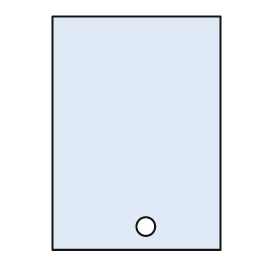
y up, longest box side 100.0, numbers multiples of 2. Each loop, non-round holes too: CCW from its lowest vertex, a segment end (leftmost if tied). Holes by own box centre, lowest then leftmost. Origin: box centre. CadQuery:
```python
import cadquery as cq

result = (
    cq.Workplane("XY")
    .moveTo(-36.0, -50.0)
    .lineTo(36.0, -50.0)
    .lineTo(36.0, 50.0)
    .lineTo(-36.0, 50.0)
    .close()
    .moveTo(4.0, -40.0)
    .circle(4.0)
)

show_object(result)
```